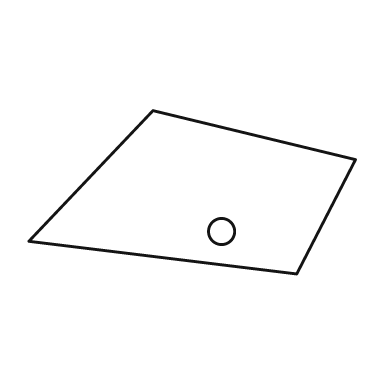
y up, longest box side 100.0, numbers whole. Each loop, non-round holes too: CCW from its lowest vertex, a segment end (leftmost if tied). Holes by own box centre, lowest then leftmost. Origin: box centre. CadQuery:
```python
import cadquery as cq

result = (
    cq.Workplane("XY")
    .moveTo(32.0, -25.0)
    .lineTo(50.0, 10.0)
    .lineTo(-12.0, 25.0)
    .lineTo(-50.0, -15.0)
    .close()
    .moveTo(9.0, -12.0)
    .circle(4.0)
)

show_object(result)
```